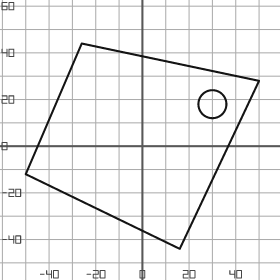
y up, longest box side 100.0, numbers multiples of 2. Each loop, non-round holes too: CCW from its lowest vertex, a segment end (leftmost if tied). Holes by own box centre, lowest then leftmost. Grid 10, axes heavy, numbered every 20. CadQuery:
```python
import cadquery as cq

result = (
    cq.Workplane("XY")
    .moveTo(16.0, -44.0)
    .lineTo(50.0, 28.0)
    .lineTo(-26.0, 44.0)
    .lineTo(-50.0, -12.0)
    .close()
    .moveTo(30.0, 18.0)
    .circle(6.0)
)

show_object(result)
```